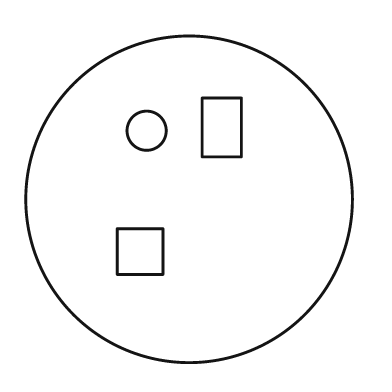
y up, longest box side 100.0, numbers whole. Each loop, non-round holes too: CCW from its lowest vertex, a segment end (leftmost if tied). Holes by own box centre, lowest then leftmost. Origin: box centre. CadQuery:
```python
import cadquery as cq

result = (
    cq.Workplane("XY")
    .moveTo(0.0, 0.0)
    .circle(50.0)
    .moveTo(-22.0, -23.0)
    .lineTo(-8.0, -23.0)
    .lineTo(-8.0, -9.0)
    .lineTo(-22.0, -9.0)
    .close()
    .moveTo(-13.0, 21.0)
    .circle(6.0)
    .moveTo(4.0, 13.0)
    .lineTo(16.0, 13.0)
    .lineTo(16.0, 31.0)
    .lineTo(4.0, 31.0)
    .close()
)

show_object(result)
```